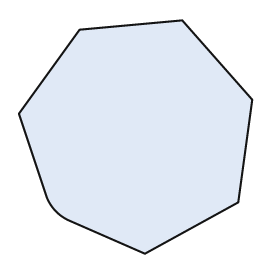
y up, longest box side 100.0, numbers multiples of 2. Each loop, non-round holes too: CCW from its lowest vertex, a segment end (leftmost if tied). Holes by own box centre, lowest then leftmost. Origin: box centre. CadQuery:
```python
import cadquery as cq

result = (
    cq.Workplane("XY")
    .moveTo(4.0, -50.0)
    .lineTo(44.0, -28.0)
    .lineTo(50.0, 16.0)
    .lineTo(20.0, 50.0)
    .lineTo(-24.0, 46.0)
    .lineTo(-50.0, 10.0)
    .lineTo(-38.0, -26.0)
    .threePointArc((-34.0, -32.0), (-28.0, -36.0))
    .close()
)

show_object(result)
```